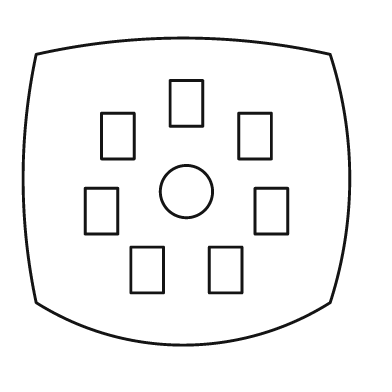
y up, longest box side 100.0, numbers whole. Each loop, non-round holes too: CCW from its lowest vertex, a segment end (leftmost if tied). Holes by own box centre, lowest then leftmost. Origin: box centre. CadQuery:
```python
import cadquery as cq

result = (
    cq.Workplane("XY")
    .moveTo(-46.0, -34.0)
    .threePointArc((-1.0, -47.0), (44.0, -34.0))
    .threePointArc((50.0, 4.0), (44.0, 42.0))
    .threePointArc((-1.0, 47.0), (-46.0, 42.0))
    .threePointArc((-50.0, 4.0), (-46.0, -34.0))
    .close()
    .moveTo(-17.0, -31.0)
    .lineTo(-7.0, -31.0)
    .lineTo(-7.0, -17.0)
    .lineTo(-17.0, -17.0)
    .close()
    .moveTo(7.0, -31.0)
    .lineTo(17.0, -31.0)
    .lineTo(17.0, -17.0)
    .lineTo(7.0, -17.0)
    .close()
    .moveTo(-31.0, -13.0)
    .lineTo(-21.0, -13.0)
    .lineTo(-21.0, 1.0)
    .lineTo(-31.0, 1.0)
    .close()
    .moveTo(21.0, -13.0)
    .lineTo(31.0, -13.0)
    .lineTo(31.0, 1.0)
    .lineTo(21.0, 1.0)
    .close()
    .moveTo(0.0, 0.0)
    .circle(8.0)
    .moveTo(-26.0, 10.0)
    .lineTo(-16.0, 10.0)
    .lineTo(-16.0, 24.0)
    .lineTo(-26.0, 24.0)
    .close()
    .moveTo(16.0, 10.0)
    .lineTo(26.0, 10.0)
    .lineTo(26.0, 24.0)
    .lineTo(16.0, 24.0)
    .close()
    .moveTo(-5.0, 20.0)
    .lineTo(5.0, 20.0)
    .lineTo(5.0, 34.0)
    .lineTo(-5.0, 34.0)
    .close()
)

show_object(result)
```